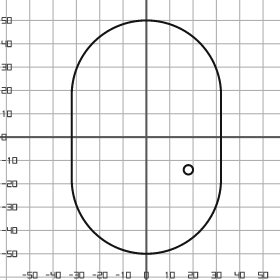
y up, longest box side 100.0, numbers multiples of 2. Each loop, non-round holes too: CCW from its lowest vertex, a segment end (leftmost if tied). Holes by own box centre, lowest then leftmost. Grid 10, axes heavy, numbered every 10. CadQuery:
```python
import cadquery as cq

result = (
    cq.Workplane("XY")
    .moveTo(-32.0, -18.0)
    .threePointArc((0.0, -50.0), (32.0, -18.0))
    .lineTo(32.0, 18.0)
    .threePointArc((0.0, 50.0), (-32.0, 18.0))
    .close()
    .moveTo(18.0, -14.0)
    .circle(2.0)
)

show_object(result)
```